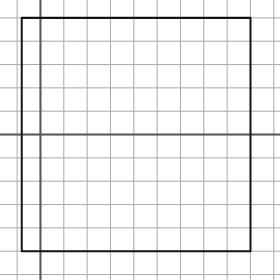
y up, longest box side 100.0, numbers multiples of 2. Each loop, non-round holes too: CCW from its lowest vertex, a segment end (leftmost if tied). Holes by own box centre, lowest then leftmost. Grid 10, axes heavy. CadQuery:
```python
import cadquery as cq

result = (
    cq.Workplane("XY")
    .moveTo(-8.0, -50.0)
    .lineTo(90.0, -50.0)
    .lineTo(90.0, 50.0)
    .lineTo(-8.0, 50.0)
    .close()
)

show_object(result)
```